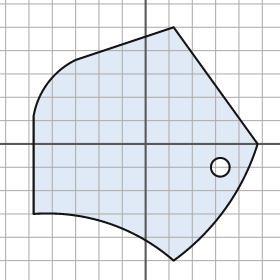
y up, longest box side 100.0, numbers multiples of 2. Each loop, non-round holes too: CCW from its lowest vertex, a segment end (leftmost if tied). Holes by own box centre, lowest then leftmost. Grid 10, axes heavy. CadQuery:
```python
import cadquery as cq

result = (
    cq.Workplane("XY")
    .moveTo(12.0, -50.0)
    .threePointArc((34.0, -28.0), (48.0, 0.0))
    .lineTo(12.0, 50.0)
    .lineTo(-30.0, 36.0)
    .threePointArc((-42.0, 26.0), (-48.0, 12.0))
    .lineTo(-48.0, -30.0)
    .threePointArc((-16.0, -34.0), (12.0, -50.0))
    .close()
    .moveTo(32.0, -10.0)
    .circle(4.0)
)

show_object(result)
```